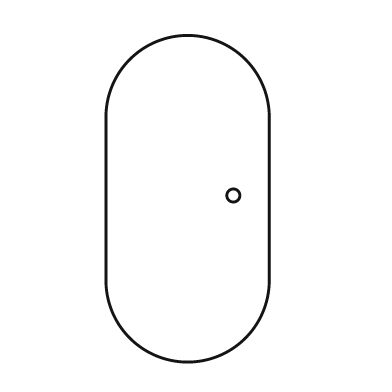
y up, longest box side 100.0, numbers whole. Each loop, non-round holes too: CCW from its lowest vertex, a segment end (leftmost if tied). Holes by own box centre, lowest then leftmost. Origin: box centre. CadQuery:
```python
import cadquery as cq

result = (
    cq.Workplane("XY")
    .moveTo(-25.0, -25.0)
    .threePointArc((0.0, -50.0), (25.0, -25.0))
    .lineTo(25.0, 25.0)
    .threePointArc((0.0, 50.0), (-25.0, 25.0))
    .close()
    .moveTo(14.0, 1.0)
    .circle(2.0)
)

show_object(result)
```